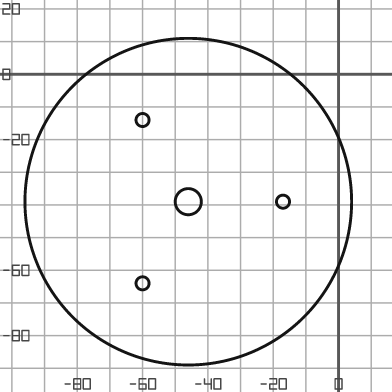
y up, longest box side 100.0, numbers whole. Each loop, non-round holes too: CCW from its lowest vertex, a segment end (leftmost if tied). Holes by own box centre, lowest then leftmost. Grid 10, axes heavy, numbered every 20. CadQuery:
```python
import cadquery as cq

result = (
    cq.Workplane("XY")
    .moveTo(-46.0, -39.0)
    .circle(50.0)
    .moveTo(-60.0, -64.0)
    .circle(2.0)
    .moveTo(-46.0, -39.0)
    .circle(4.0)
    .moveTo(-17.0, -39.0)
    .circle(2.0)
    .moveTo(-60.0, -14.0)
    .circle(2.0)
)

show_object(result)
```